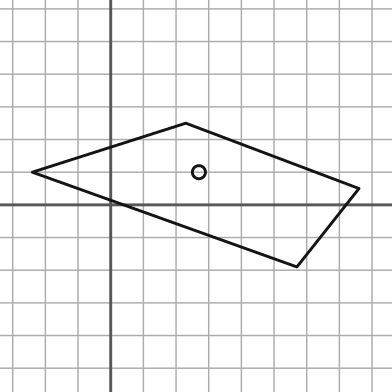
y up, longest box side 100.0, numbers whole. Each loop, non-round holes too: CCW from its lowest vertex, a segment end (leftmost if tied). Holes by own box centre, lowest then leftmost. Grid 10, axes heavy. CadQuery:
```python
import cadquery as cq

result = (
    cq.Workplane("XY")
    .moveTo(57.0, -19.0)
    .lineTo(76.0, 5.0)
    .lineTo(23.0, 25.0)
    .lineTo(-24.0, 10.0)
    .close()
    .moveTo(27.0, 10.0)
    .circle(2.0)
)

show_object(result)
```